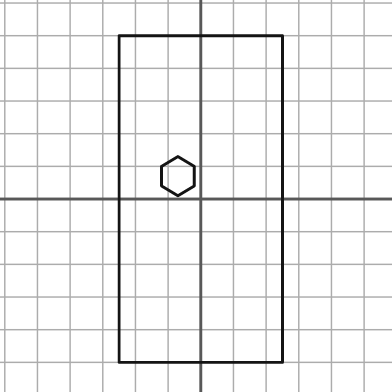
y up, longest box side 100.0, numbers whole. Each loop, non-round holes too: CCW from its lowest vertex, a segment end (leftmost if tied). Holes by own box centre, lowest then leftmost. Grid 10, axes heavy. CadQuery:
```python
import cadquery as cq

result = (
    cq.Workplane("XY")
    .moveTo(-25.0, -50.0)
    .lineTo(25.0, -50.0)
    .lineTo(25.0, 50.0)
    .lineTo(-25.0, 50.0)
    .close()
    .moveTo(-7.0, 1.0)
    .lineTo(-2.0, 4.0)
    .lineTo(-2.0, 10.0)
    .lineTo(-7.0, 13.0)
    .lineTo(-12.0, 10.0)
    .lineTo(-12.0, 4.0)
    .close()
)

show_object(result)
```